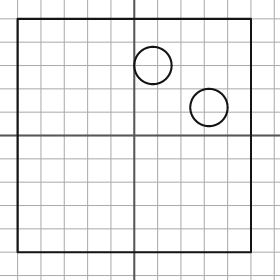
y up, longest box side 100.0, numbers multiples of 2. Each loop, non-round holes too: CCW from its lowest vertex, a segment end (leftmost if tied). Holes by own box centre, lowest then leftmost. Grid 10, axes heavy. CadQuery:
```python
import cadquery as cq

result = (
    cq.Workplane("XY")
    .moveTo(-50.0, -50.0)
    .lineTo(50.0, -50.0)
    .lineTo(50.0, 50.0)
    .lineTo(-50.0, 50.0)
    .close()
    .moveTo(32.0, 12.0)
    .circle(8.0)
    .moveTo(8.0, 30.0)
    .circle(8.0)
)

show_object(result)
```